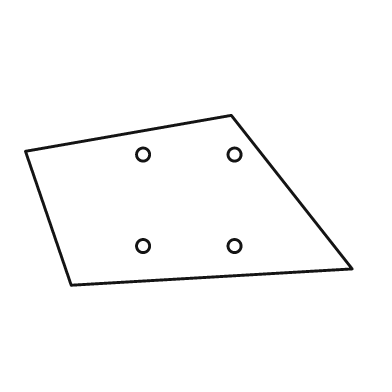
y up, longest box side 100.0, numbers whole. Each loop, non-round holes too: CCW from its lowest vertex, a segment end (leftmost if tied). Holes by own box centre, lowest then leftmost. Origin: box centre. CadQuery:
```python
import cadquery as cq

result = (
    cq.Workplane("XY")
    .moveTo(-36.0, -26.0)
    .lineTo(50.0, -21.0)
    .lineTo(13.0, 26.0)
    .lineTo(-50.0, 15.0)
    .close()
    .moveTo(-14.0, -14.0)
    .circle(2.0)
    .moveTo(14.0, -14.0)
    .circle(2.0)
    .moveTo(-14.0, 14.0)
    .circle(2.0)
    .moveTo(14.0, 14.0)
    .circle(2.0)
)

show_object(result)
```